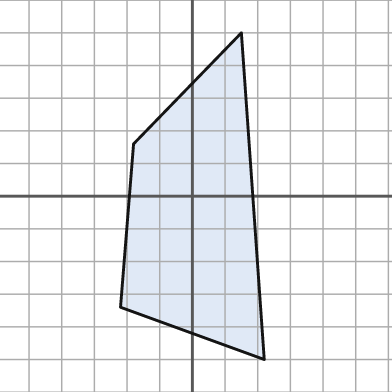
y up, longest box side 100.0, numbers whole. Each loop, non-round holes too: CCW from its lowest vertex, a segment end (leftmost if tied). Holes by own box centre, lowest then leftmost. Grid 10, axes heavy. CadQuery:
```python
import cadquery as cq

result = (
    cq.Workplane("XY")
    .moveTo(22.0, -50.0)
    .lineTo(15.0, 50.0)
    .lineTo(-18.0, 16.0)
    .lineTo(-22.0, -34.0)
    .close()
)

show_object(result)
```